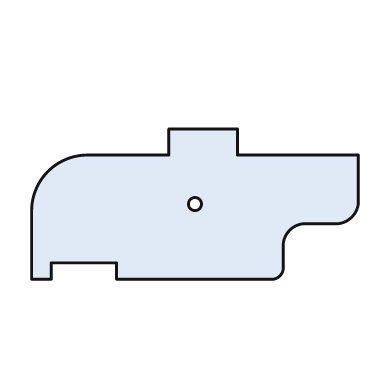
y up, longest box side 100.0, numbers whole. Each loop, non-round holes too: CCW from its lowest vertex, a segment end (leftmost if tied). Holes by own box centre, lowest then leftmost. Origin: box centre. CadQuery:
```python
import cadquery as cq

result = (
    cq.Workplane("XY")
    .moveTo(-50.0, -23.0)
    .lineTo(-44.0, -23.0)
    .lineTo(-44.0, -18.0)
    .lineTo(-24.0, -18.0)
    .lineTo(-24.0, -23.0)
    .lineTo(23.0, -23.0)
    .threePointArc((26.0, -22.0), (27.0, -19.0))
    .lineTo(27.0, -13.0)
    .threePointArc((29.0, -8.0), (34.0, -6.0))
    .lineTo(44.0, -6.0)
    .threePointArc((48.0, -4.0), (50.0, 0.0))
    .lineTo(50.0, 15.0)
    .lineTo(13.0, 15.0)
    .lineTo(13.0, 23.0)
    .lineTo(-8.0, 23.0)
    .lineTo(-8.0, 15.0)
    .lineTo(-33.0, 15.0)
    .threePointArc((-45.0, 10.0), (-50.0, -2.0))
    .close()
    .moveTo(0.0, 0.0)
    .circle(2.0)
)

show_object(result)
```